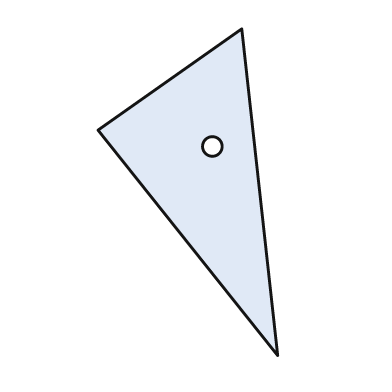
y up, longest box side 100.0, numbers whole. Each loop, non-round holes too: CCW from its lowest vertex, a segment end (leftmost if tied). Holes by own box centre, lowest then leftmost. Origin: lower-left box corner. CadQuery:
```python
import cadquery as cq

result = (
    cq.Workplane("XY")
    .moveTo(55.0, 0.0)
    .lineTo(44.0, 100.0)
    .lineTo(0.0, 69.0)
    .close()
    .moveTo(35.0, 64.0)
    .circle(3.0)
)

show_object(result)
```